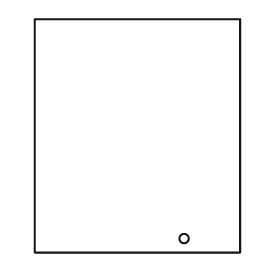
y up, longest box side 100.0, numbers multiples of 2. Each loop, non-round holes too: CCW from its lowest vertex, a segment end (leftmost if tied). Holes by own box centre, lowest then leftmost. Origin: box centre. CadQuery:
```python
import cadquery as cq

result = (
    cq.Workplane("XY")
    .moveTo(-44.0, -50.0)
    .lineTo(44.0, -50.0)
    .lineTo(44.0, 50.0)
    .lineTo(-44.0, 50.0)
    .close()
    .moveTo(20.0, -44.0)
    .circle(2.0)
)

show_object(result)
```